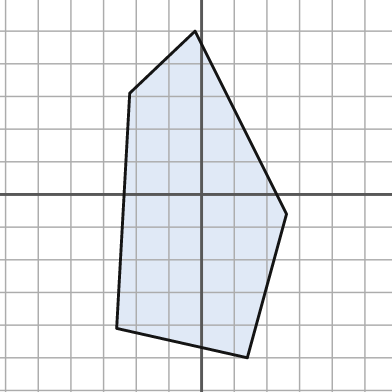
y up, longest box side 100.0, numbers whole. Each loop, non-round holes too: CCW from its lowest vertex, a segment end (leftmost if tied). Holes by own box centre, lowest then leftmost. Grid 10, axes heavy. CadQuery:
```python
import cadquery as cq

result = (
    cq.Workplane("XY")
    .moveTo(14.0, -50.0)
    .lineTo(26.0, -6.0)
    .lineTo(-2.0, 50.0)
    .lineTo(-22.0, 31.0)
    .lineTo(-26.0, -41.0)
    .close()
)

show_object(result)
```